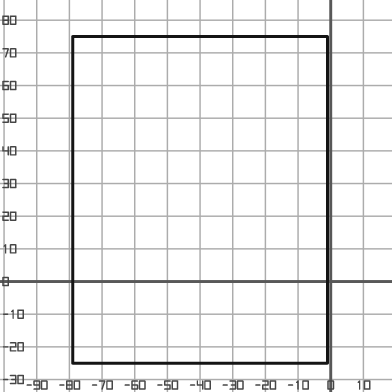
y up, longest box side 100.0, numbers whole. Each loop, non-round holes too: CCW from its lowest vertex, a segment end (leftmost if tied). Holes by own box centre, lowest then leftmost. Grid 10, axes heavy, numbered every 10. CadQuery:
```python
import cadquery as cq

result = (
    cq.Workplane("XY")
    .moveTo(-79.0, -25.0)
    .lineTo(-1.0, -25.0)
    .lineTo(-1.0, 75.0)
    .lineTo(-79.0, 75.0)
    .close()
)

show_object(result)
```